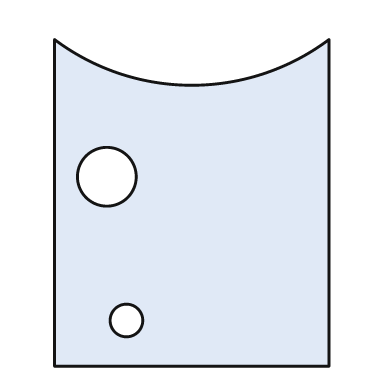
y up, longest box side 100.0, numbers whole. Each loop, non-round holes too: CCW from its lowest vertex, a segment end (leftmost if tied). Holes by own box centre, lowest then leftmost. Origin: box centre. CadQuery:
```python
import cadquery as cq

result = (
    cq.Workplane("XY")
    .moveTo(-42.0, -50.0)
    .lineTo(42.0, -50.0)
    .lineTo(42.0, 50.0)
    .threePointArc((0.0, 36.0), (-42.0, 50.0))
    .close()
    .moveTo(-20.0, -36.0)
    .circle(5.0)
    .moveTo(-26.0, 8.0)
    .circle(9.0)
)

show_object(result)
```